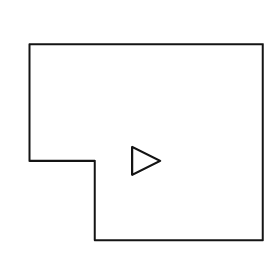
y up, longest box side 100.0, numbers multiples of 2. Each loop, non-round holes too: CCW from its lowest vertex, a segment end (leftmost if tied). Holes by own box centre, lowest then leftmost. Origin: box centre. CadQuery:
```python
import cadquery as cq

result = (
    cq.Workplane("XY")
    .moveTo(-22.0, -42.0)
    .lineTo(50.0, -42.0)
    .lineTo(50.0, 42.0)
    .lineTo(-50.0, 42.0)
    .lineTo(-50.0, -8.0)
    .lineTo(-22.0, -8.0)
    .close()
    .moveTo(-6.0, -14.0)
    .lineTo(6.0, -8.0)
    .lineTo(-6.0, -2.0)
    .close()
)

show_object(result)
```